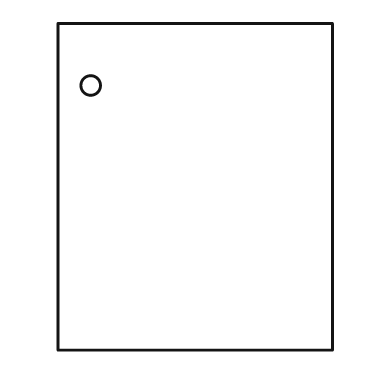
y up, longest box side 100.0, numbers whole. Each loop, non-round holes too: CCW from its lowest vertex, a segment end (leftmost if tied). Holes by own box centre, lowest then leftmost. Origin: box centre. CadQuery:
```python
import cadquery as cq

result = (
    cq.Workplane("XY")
    .moveTo(-42.0, -50.0)
    .lineTo(42.0, -50.0)
    .lineTo(42.0, 50.0)
    .lineTo(-42.0, 50.0)
    .close()
    .moveTo(-32.0, 31.0)
    .circle(3.0)
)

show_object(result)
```